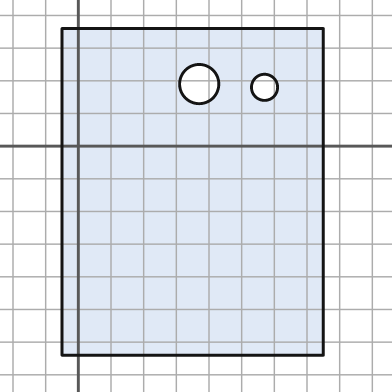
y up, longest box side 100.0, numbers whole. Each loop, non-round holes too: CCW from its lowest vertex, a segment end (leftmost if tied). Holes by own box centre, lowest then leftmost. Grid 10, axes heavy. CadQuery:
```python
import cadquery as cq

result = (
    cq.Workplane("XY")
    .moveTo(-5.0, -64.0)
    .lineTo(75.0, -64.0)
    .lineTo(75.0, 36.0)
    .lineTo(-5.0, 36.0)
    .close()
    .moveTo(57.0, 18.0)
    .circle(4.0)
    .moveTo(37.0, 19.0)
    .circle(6.0)
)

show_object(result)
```